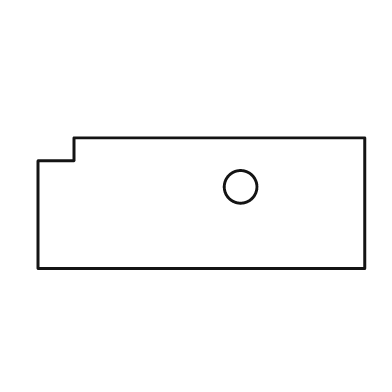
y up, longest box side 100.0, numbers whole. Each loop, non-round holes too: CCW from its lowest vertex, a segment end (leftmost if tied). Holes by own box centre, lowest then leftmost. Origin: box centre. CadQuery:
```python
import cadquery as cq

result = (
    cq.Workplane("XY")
    .moveTo(-50.0, -20.0)
    .lineTo(50.0, -20.0)
    .lineTo(50.0, 20.0)
    .lineTo(-39.0, 20.0)
    .lineTo(-39.0, 13.0)
    .lineTo(-50.0, 13.0)
    .close()
    .moveTo(12.0, 5.0)
    .circle(5.0)
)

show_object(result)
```